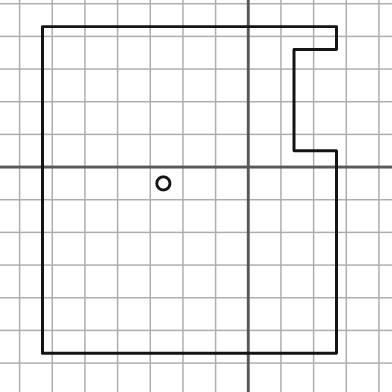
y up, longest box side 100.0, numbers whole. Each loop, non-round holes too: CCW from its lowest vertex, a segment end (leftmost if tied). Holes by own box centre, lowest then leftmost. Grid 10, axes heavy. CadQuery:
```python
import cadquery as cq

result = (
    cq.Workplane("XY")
    .moveTo(-63.0, -57.0)
    .lineTo(27.0, -57.0)
    .lineTo(27.0, 5.0)
    .lineTo(14.0, 5.0)
    .lineTo(14.0, 36.0)
    .lineTo(27.0, 36.0)
    .lineTo(27.0, 43.0)
    .lineTo(-63.0, 43.0)
    .close()
    .moveTo(-26.0, -5.0)
    .circle(2.0)
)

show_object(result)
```